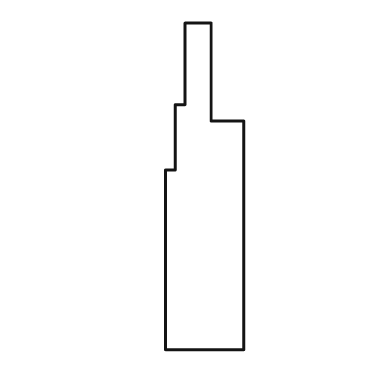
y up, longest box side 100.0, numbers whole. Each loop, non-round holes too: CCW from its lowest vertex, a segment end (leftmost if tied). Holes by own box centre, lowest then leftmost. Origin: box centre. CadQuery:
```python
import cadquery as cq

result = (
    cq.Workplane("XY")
    .moveTo(-12.0, -50.0)
    .lineTo(12.0, -50.0)
    .lineTo(12.0, 20.0)
    .lineTo(2.0, 20.0)
    .lineTo(2.0, 50.0)
    .lineTo(-6.0, 50.0)
    .lineTo(-6.0, 25.0)
    .lineTo(-9.0, 25.0)
    .lineTo(-9.0, 5.0)
    .lineTo(-12.0, 5.0)
    .close()
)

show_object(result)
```